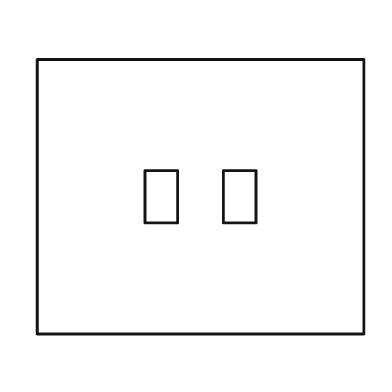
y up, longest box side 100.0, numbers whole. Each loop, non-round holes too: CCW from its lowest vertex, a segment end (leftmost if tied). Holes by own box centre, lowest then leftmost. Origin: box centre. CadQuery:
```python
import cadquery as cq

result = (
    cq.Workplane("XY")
    .moveTo(-50.0, -42.0)
    .lineTo(50.0, -42.0)
    .lineTo(50.0, 42.0)
    .lineTo(-50.0, 42.0)
    .close()
    .moveTo(-17.0, -8.0)
    .lineTo(-7.0, -8.0)
    .lineTo(-7.0, 8.0)
    .lineTo(-17.0, 8.0)
    .close()
    .moveTo(7.0, -8.0)
    .lineTo(17.0, -8.0)
    .lineTo(17.0, 8.0)
    .lineTo(7.0, 8.0)
    .close()
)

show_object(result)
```